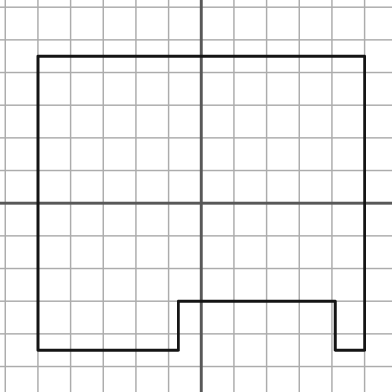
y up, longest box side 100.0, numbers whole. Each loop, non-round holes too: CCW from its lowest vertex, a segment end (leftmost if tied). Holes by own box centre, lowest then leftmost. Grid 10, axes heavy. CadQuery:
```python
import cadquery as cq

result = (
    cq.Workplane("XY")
    .moveTo(-50.0, -45.0)
    .lineTo(-7.0, -45.0)
    .lineTo(-7.0, -30.0)
    .lineTo(41.0, -30.0)
    .lineTo(41.0, -45.0)
    .lineTo(50.0, -45.0)
    .lineTo(50.0, 45.0)
    .lineTo(-50.0, 45.0)
    .close()
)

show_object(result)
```